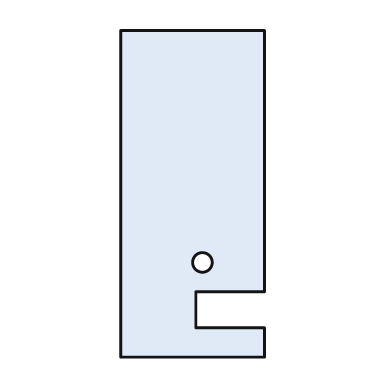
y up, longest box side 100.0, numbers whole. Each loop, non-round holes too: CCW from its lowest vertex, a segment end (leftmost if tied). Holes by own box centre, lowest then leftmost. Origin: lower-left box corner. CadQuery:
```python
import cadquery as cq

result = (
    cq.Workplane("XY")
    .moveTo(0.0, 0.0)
    .lineTo(44.0, 0.0)
    .lineTo(44.0, 9.0)
    .lineTo(23.0, 9.0)
    .lineTo(23.0, 20.0)
    .lineTo(44.0, 20.0)
    .lineTo(44.0, 100.0)
    .lineTo(0.0, 100.0)
    .close()
    .moveTo(25.0, 29.0)
    .circle(3.0)
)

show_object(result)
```